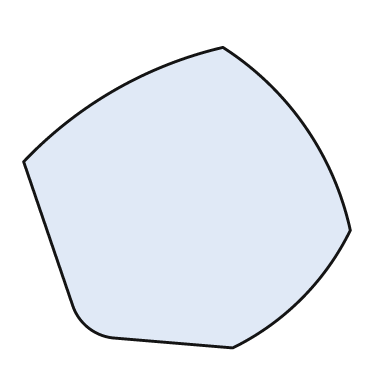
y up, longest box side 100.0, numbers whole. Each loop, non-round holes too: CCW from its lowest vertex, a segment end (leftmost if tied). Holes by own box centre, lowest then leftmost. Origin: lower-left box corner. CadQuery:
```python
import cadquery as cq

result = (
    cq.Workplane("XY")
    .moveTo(64.0, 0.0)
    .threePointArc((85.0, 15.0), (100.0, 36.0))
    .threePointArc((86.0, 68.0), (61.0, 92.0))
    .threePointArc((28.0, 79.0), (0.0, 57.0))
    .lineTo(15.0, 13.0)
    .threePointArc((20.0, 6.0), (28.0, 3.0))
    .close()
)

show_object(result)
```